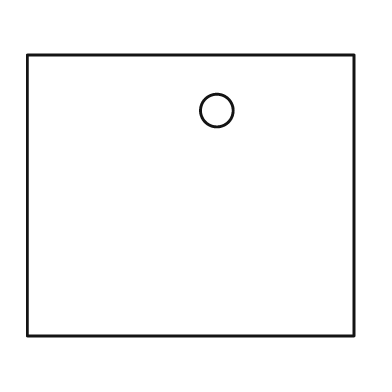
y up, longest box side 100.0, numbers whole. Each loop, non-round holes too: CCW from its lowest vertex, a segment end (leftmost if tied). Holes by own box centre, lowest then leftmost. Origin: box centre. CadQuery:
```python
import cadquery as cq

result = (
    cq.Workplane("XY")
    .moveTo(-50.0, -43.0)
    .lineTo(50.0, -43.0)
    .lineTo(50.0, 43.0)
    .lineTo(-50.0, 43.0)
    .close()
    .moveTo(8.0, 26.0)
    .circle(5.0)
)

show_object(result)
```